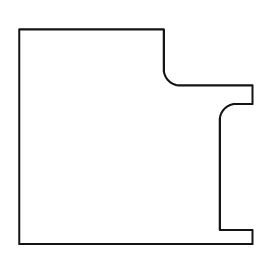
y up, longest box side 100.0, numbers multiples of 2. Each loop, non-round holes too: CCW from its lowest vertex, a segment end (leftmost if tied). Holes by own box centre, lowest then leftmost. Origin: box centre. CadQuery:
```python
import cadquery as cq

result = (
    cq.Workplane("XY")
    .moveTo(-50.0, -46.0)
    .lineTo(50.0, -46.0)
    .lineTo(50.0, -40.0)
    .lineTo(36.0, -40.0)
    .lineTo(36.0, 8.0)
    .threePointArc((38.0, 12.0), (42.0, 14.0))
    .lineTo(50.0, 14.0)
    .lineTo(50.0, 22.0)
    .lineTo(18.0, 22.0)
    .threePointArc((14.0, 24.0), (12.0, 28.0))
    .lineTo(12.0, 46.0)
    .lineTo(-50.0, 46.0)
    .close()
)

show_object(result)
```